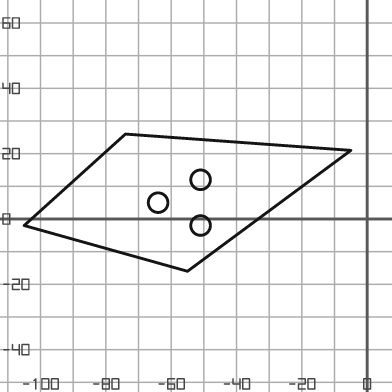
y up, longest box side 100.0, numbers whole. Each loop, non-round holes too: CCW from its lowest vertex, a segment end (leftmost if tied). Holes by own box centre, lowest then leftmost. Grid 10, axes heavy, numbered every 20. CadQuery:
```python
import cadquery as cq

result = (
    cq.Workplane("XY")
    .moveTo(-55.0, -16.0)
    .lineTo(-5.0, 21.0)
    .lineTo(-74.0, 26.0)
    .lineTo(-105.0, -2.0)
    .close()
    .moveTo(-51.0, -2.0)
    .circle(3.0)
    .moveTo(-64.0, 5.0)
    .circle(3.0)
    .moveTo(-51.0, 12.0)
    .circle(3.0)
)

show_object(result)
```